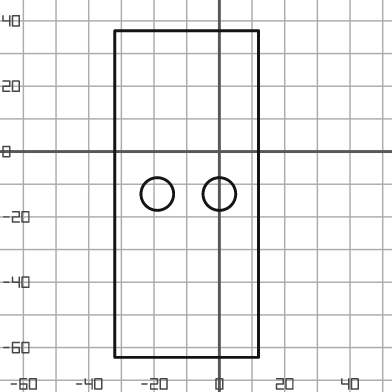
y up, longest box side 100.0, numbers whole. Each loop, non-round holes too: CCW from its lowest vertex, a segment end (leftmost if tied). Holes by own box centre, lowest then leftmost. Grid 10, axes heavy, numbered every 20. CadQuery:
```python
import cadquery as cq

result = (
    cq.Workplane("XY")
    .moveTo(-32.0, -63.0)
    .lineTo(12.0, -63.0)
    .lineTo(12.0, 37.0)
    .lineTo(-32.0, 37.0)
    .close()
    .moveTo(-19.0, -13.0)
    .circle(5.0)
    .moveTo(0.0, -13.0)
    .circle(5.0)
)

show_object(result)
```